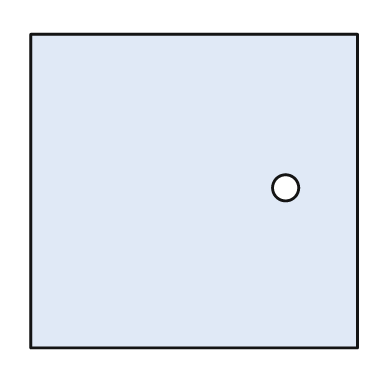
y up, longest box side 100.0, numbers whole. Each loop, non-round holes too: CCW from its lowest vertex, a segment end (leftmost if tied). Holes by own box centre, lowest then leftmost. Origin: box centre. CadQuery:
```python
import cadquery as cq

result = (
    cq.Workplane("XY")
    .moveTo(-50.0, -48.0)
    .lineTo(50.0, -48.0)
    .lineTo(50.0, 48.0)
    .lineTo(-50.0, 48.0)
    .close()
    .moveTo(28.0, 1.0)
    .circle(4.0)
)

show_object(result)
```